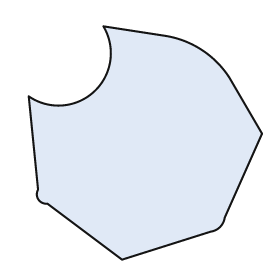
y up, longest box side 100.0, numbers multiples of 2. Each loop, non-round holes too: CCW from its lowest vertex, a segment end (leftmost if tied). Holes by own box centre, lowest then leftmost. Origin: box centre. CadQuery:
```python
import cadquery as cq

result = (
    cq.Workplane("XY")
    .moveTo(-10.0, -50.0)
    .lineTo(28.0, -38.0)
    .threePointArc((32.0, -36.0), (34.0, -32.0))
    .lineTo(50.0, 4.0)
    .lineTo(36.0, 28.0)
    .threePointArc((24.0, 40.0), (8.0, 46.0))
    .lineTo(-18.0, 50.0)
    .threePointArc((-22.0, 22.0), (-50.0, 20.0))
    .lineTo(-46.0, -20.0)
    .threePointArc((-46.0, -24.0), (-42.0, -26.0))
    .close()
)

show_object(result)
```